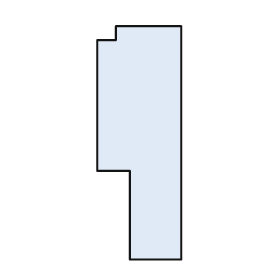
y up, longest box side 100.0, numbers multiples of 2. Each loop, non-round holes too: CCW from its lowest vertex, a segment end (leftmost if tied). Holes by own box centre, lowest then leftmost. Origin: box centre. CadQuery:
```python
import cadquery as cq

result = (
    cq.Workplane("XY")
    .moveTo(-4.0, -50.0)
    .lineTo(18.0, -50.0)
    .lineTo(18.0, 50.0)
    .lineTo(-10.0, 50.0)
    .lineTo(-10.0, 44.0)
    .lineTo(-18.0, 44.0)
    .lineTo(-18.0, -12.0)
    .lineTo(-4.0, -12.0)
    .close()
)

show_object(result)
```